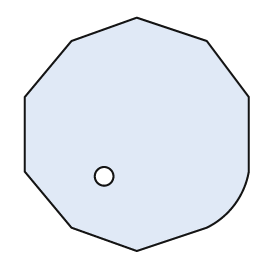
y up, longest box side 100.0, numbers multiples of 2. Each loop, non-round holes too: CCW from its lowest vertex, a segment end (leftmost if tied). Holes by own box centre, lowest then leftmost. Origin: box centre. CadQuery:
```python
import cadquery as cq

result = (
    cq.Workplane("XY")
    .moveTo(0.0, -50.0)
    .lineTo(30.0, -40.0)
    .threePointArc((42.0, -30.0), (48.0, -16.0))
    .lineTo(48.0, 16.0)
    .lineTo(30.0, 40.0)
    .lineTo(0.0, 50.0)
    .lineTo(-28.0, 40.0)
    .lineTo(-48.0, 16.0)
    .lineTo(-48.0, -16.0)
    .lineTo(-28.0, -40.0)
    .close()
    .moveTo(-14.0, -18.0)
    .circle(4.0)
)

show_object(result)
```